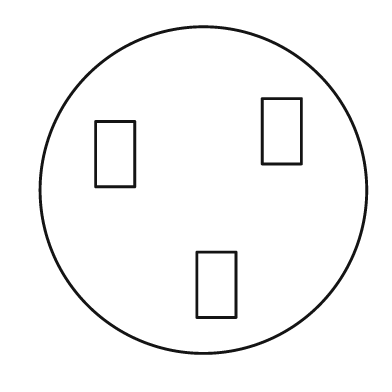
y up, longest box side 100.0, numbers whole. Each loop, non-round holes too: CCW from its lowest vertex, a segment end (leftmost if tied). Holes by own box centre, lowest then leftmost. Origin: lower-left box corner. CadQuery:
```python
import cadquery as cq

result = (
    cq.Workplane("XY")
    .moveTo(50.0, 50.0)
    .circle(50.0)
    .moveTo(48.0, 11.0)
    .lineTo(60.0, 11.0)
    .lineTo(60.0, 31.0)
    .lineTo(48.0, 31.0)
    .close()
    .moveTo(17.0, 51.0)
    .lineTo(29.0, 51.0)
    .lineTo(29.0, 71.0)
    .lineTo(17.0, 71.0)
    .close()
    .moveTo(68.0, 58.0)
    .lineTo(80.0, 58.0)
    .lineTo(80.0, 78.0)
    .lineTo(68.0, 78.0)
    .close()
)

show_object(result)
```